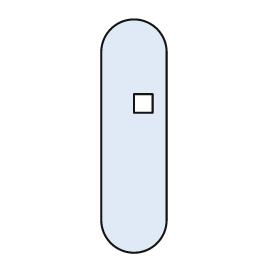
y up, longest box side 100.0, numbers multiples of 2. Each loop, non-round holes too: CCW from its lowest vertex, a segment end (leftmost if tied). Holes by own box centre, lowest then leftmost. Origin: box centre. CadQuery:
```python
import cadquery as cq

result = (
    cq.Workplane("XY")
    .moveTo(-14.0, -36.0)
    .threePointArc((0.0, -50.0), (14.0, -36.0))
    .lineTo(14.0, 36.0)
    .threePointArc((0.0, 50.0), (-14.0, 36.0))
    .close()
    .moveTo(0.0, 10.0)
    .lineTo(8.0, 10.0)
    .lineTo(8.0, 18.0)
    .lineTo(0.0, 18.0)
    .close()
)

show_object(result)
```